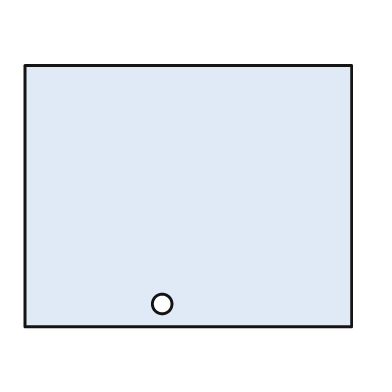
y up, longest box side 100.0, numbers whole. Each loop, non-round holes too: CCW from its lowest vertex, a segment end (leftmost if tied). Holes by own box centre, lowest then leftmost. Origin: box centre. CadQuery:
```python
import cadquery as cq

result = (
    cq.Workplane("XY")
    .moveTo(-50.0, -40.0)
    .lineTo(50.0, -40.0)
    .lineTo(50.0, 40.0)
    .lineTo(-50.0, 40.0)
    .close()
    .moveTo(-8.0, -33.0)
    .circle(3.0)
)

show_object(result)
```